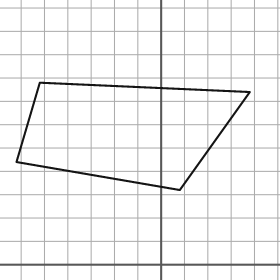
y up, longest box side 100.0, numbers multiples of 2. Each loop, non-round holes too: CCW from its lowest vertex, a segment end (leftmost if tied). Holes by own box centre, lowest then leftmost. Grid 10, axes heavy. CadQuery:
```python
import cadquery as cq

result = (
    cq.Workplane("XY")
    .moveTo(8.0, 32.0)
    .lineTo(38.0, 74.0)
    .lineTo(-52.0, 78.0)
    .lineTo(-62.0, 44.0)
    .close()
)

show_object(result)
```